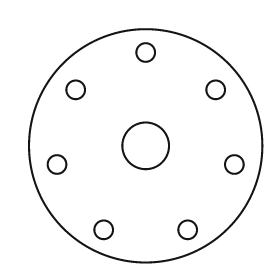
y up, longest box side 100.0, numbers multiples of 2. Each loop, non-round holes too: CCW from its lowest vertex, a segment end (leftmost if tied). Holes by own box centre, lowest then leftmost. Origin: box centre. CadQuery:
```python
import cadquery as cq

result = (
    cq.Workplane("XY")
    .moveTo(0.0, 0.0)
    .circle(50.0)
    .moveTo(-18.0, -36.0)
    .circle(4.0)
    .moveTo(18.0, -36.0)
    .circle(4.0)
    .moveTo(-38.0, -8.0)
    .circle(4.0)
    .moveTo(38.0, -8.0)
    .circle(4.0)
    .moveTo(0.0, 0.0)
    .circle(10.0)
    .moveTo(-30.0, 24.0)
    .circle(4.0)
    .moveTo(30.0, 24.0)
    .circle(4.0)
    .moveTo(0.0, 40.0)
    .circle(4.0)
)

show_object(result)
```